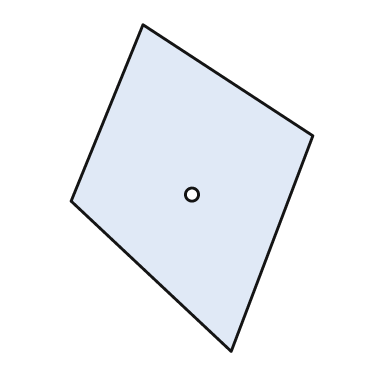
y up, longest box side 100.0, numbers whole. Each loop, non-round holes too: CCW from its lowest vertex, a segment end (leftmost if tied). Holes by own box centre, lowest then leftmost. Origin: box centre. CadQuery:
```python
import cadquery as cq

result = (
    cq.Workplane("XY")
    .moveTo(12.0, -50.0)
    .lineTo(37.0, 16.0)
    .lineTo(-15.0, 50.0)
    .lineTo(-37.0, -4.0)
    .close()
    .moveTo(0.0, -2.0)
    .circle(2.0)
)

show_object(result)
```